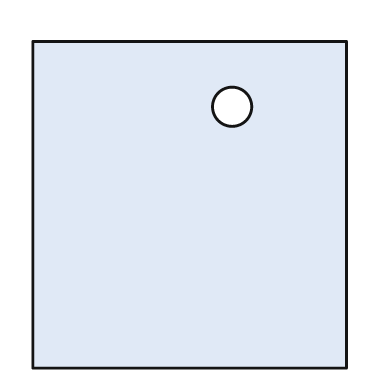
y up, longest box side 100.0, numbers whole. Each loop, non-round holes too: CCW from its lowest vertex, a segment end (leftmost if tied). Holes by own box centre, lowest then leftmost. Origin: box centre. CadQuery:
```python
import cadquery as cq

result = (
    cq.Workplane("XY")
    .moveTo(-48.0, -50.0)
    .lineTo(48.0, -50.0)
    .lineTo(48.0, 50.0)
    .lineTo(-48.0, 50.0)
    .close()
    .moveTo(13.0, 30.0)
    .circle(6.0)
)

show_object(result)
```